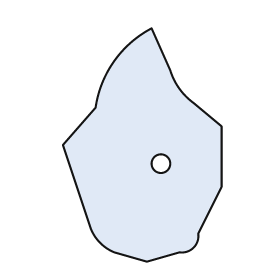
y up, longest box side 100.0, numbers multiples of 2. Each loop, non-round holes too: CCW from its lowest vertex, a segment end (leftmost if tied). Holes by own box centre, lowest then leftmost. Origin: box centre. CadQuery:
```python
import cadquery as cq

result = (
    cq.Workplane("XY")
    .moveTo(2.0, -50.0)
    .lineTo(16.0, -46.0)
    .threePointArc((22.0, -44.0), (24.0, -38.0))
    .lineTo(34.0, -18.0)
    .lineTo(34.0, 8.0)
    .lineTo(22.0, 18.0)
    .threePointArc((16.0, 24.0), (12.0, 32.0))
    .lineTo(4.0, 50.0)
    .threePointArc((-12.0, 36.0), (-20.0, 16.0))
    .lineTo(-34.0, 0.0)
    .lineTo(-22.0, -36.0)
    .threePointArc((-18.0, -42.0), (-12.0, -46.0))
    .close()
    .moveTo(8.0, -8.0)
    .circle(4.0)
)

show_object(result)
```